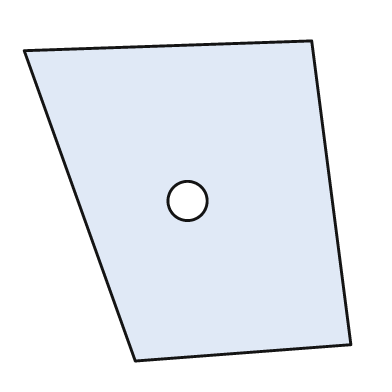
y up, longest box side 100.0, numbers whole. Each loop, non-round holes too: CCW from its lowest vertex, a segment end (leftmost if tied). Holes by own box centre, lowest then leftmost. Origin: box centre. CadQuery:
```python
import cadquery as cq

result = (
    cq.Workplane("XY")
    .moveTo(-16.0, -49.0)
    .lineTo(50.0, -44.0)
    .lineTo(38.0, 49.0)
    .lineTo(-50.0, 46.0)
    .close()
    .moveTo(0.0, 0.0)
    .circle(6.0)
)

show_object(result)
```